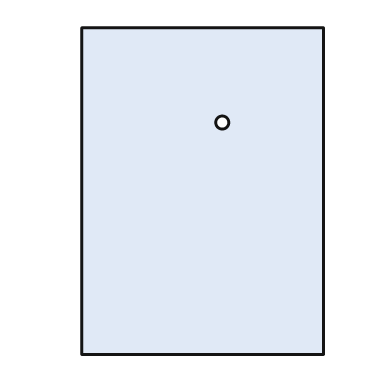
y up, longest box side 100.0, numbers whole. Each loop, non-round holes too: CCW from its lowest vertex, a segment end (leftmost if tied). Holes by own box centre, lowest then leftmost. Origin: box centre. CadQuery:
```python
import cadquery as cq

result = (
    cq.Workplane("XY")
    .moveTo(-37.0, -50.0)
    .lineTo(37.0, -50.0)
    .lineTo(37.0, 50.0)
    .lineTo(-37.0, 50.0)
    .close()
    .moveTo(6.0, 21.0)
    .circle(2.0)
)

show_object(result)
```